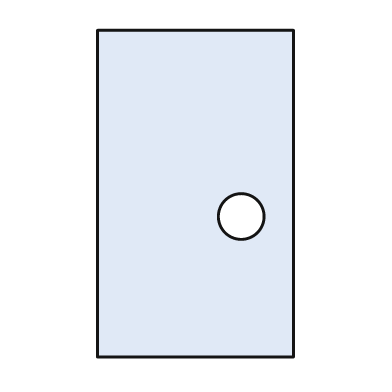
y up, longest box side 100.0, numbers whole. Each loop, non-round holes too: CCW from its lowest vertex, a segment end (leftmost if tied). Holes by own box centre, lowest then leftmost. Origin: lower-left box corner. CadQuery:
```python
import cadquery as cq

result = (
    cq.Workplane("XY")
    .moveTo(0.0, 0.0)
    .lineTo(60.0, 0.0)
    .lineTo(60.0, 100.0)
    .lineTo(0.0, 100.0)
    .close()
    .moveTo(44.0, 43.0)
    .circle(7.0)
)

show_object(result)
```